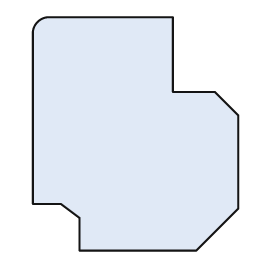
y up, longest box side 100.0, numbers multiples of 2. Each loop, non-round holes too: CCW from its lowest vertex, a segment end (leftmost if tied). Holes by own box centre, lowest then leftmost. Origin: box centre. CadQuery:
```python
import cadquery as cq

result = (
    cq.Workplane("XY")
    .moveTo(-24.0, -50.0)
    .lineTo(26.0, -50.0)
    .lineTo(44.0, -32.0)
    .lineTo(44.0, 8.0)
    .lineTo(34.0, 18.0)
    .lineTo(16.0, 18.0)
    .lineTo(16.0, 50.0)
    .lineTo(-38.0, 50.0)
    .threePointArc((-42.0, 48.0), (-44.0, 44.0))
    .lineTo(-44.0, -30.0)
    .lineTo(-32.0, -30.0)
    .lineTo(-24.0, -36.0)
    .close()
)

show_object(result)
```